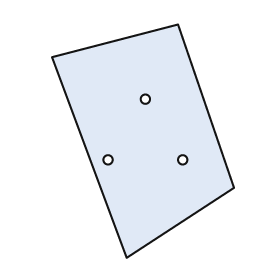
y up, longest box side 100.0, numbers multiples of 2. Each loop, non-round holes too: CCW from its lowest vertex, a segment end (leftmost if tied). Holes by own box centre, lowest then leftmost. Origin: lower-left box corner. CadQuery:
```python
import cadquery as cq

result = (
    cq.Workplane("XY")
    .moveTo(32.0, 0.0)
    .lineTo(78.0, 30.0)
    .lineTo(54.0, 100.0)
    .lineTo(0.0, 86.0)
    .close()
    .moveTo(24.0, 42.0)
    .circle(2.0)
    .moveTo(56.0, 42.0)
    .circle(2.0)
    .moveTo(40.0, 68.0)
    .circle(2.0)
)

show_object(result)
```